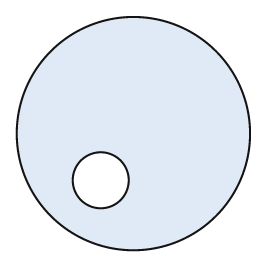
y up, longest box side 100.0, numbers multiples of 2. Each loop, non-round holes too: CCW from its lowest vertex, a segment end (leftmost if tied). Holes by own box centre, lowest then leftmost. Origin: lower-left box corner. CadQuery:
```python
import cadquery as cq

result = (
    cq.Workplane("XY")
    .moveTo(50.0, 50.0)
    .circle(50.0)
    .moveTo(36.0, 30.0)
    .circle(12.0)
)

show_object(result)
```